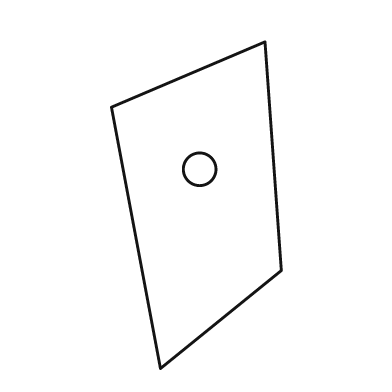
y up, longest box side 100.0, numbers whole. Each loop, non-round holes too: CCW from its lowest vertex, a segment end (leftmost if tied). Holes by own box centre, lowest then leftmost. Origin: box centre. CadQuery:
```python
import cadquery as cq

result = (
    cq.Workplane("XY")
    .moveTo(-11.0, -50.0)
    .lineTo(26.0, -20.0)
    .lineTo(21.0, 50.0)
    .lineTo(-26.0, 30.0)
    .close()
    .moveTo(1.0, 11.0)
    .circle(5.0)
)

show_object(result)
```